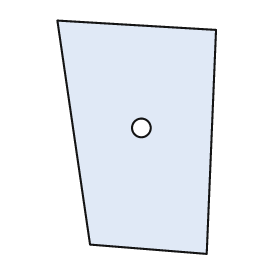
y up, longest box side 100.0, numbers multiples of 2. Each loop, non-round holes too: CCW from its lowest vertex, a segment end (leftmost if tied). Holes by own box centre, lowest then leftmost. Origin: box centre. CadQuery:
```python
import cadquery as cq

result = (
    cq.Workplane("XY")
    .moveTo(30.0, -50.0)
    .lineTo(34.0, 46.0)
    .lineTo(-34.0, 50.0)
    .lineTo(-20.0, -46.0)
    .close()
    .moveTo(2.0, 4.0)
    .circle(4.0)
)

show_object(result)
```